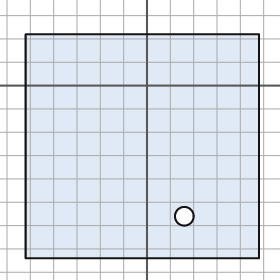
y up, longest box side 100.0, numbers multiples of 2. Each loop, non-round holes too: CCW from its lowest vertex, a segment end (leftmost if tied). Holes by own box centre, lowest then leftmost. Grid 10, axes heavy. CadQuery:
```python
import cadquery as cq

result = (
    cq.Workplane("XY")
    .moveTo(-52.0, -74.0)
    .lineTo(48.0, -74.0)
    .lineTo(48.0, 22.0)
    .lineTo(-52.0, 22.0)
    .close()
    .moveTo(16.0, -56.0)
    .circle(4.0)
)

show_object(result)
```